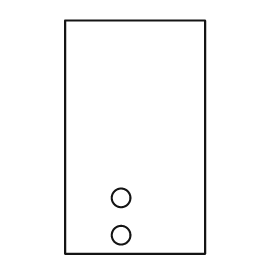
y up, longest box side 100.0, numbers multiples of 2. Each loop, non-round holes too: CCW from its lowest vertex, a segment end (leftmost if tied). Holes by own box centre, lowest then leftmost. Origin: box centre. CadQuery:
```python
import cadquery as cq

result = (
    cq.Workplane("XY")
    .moveTo(-30.0, -50.0)
    .lineTo(30.0, -50.0)
    .lineTo(30.0, 50.0)
    .lineTo(-30.0, 50.0)
    .close()
    .moveTo(-6.0, -42.0)
    .circle(4.0)
    .moveTo(-6.0, -26.0)
    .circle(4.0)
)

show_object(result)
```